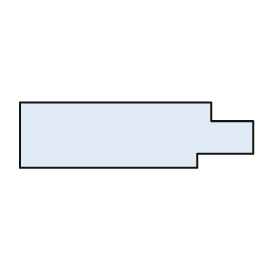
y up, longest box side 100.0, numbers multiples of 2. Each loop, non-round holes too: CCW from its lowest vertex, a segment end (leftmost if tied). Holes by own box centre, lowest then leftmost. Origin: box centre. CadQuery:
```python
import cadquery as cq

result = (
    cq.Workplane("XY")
    .moveTo(-50.0, -14.0)
    .lineTo(26.0, -14.0)
    .lineTo(26.0, -8.0)
    .lineTo(50.0, -8.0)
    .lineTo(50.0, 6.0)
    .lineTo(32.0, 6.0)
    .lineTo(32.0, 14.0)
    .lineTo(-50.0, 14.0)
    .close()
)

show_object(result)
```